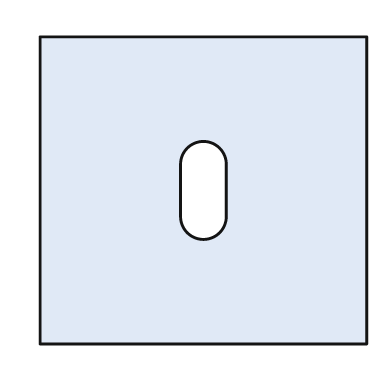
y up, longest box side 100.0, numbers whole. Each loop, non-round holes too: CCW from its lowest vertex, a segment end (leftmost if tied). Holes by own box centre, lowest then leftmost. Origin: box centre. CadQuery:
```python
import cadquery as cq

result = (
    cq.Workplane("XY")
    .moveTo(-50.0, -47.0)
    .lineTo(50.0, -47.0)
    .lineTo(50.0, 47.0)
    .lineTo(-50.0, 47.0)
    .close()
    .moveTo(-7.0, -8.0)
    .threePointArc((0.0, -15.0), (7.0, -8.0))
    .lineTo(7.0, 8.0)
    .threePointArc((0.0, 15.0), (-7.0, 8.0))
    .close()
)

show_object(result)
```